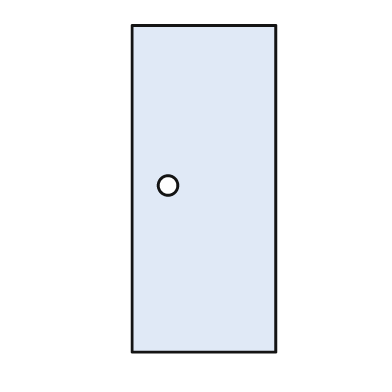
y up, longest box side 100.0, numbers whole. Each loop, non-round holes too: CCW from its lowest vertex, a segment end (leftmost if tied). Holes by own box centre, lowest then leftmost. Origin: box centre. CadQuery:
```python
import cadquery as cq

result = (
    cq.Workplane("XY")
    .moveTo(-22.0, -50.0)
    .lineTo(22.0, -50.0)
    .lineTo(22.0, 50.0)
    .lineTo(-22.0, 50.0)
    .close()
    .moveTo(-11.0, 1.0)
    .circle(3.0)
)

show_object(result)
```